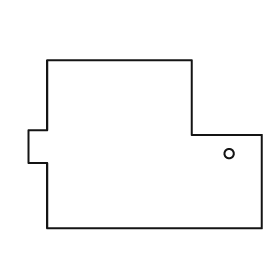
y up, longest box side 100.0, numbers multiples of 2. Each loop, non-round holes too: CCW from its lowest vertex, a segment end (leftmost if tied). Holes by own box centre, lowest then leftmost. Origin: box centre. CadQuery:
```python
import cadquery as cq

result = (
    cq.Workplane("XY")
    .moveTo(-42.0, -36.0)
    .lineTo(50.0, -36.0)
    .lineTo(50.0, 4.0)
    .lineTo(20.0, 4.0)
    .lineTo(20.0, 36.0)
    .lineTo(-42.0, 36.0)
    .lineTo(-42.0, 6.0)
    .lineTo(-50.0, 6.0)
    .lineTo(-50.0, -8.0)
    .lineTo(-42.0, -8.0)
    .close()
    .moveTo(36.0, -4.0)
    .circle(2.0)
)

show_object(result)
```